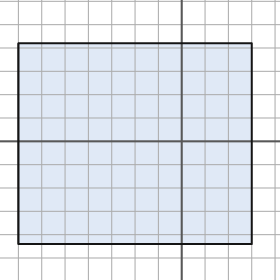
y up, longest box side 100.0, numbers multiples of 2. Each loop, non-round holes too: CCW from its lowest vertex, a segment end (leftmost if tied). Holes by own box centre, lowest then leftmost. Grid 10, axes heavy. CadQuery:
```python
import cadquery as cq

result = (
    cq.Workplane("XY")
    .moveTo(-70.0, -44.0)
    .lineTo(30.0, -44.0)
    .lineTo(30.0, 42.0)
    .lineTo(-70.0, 42.0)
    .close()
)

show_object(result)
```